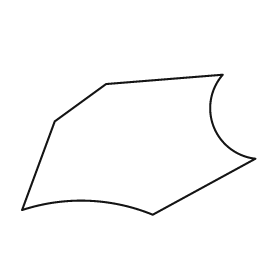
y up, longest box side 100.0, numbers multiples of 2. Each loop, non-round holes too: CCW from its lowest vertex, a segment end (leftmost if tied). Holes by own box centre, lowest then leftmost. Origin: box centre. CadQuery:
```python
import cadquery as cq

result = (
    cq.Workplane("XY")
    .moveTo(6.0, -30.0)
    .lineTo(50.0, -6.0)
    .threePointArc((32.0, 8.0), (36.0, 30.0))
    .lineTo(-14.0, 26.0)
    .lineTo(-36.0, 10.0)
    .lineTo(-50.0, -28.0)
    .threePointArc((-22.0, -24.0), (6.0, -30.0))
    .close()
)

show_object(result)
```